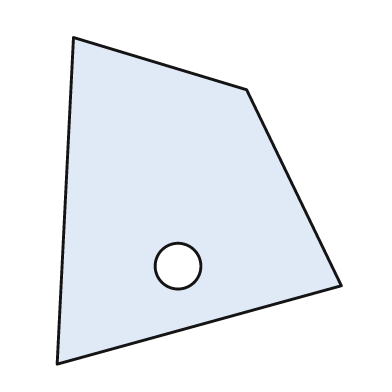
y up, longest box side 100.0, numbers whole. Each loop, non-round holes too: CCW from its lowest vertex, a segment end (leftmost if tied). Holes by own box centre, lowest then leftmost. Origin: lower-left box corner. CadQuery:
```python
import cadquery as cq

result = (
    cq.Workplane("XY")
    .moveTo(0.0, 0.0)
    .lineTo(87.0, 24.0)
    .lineTo(58.0, 84.0)
    .lineTo(5.0, 100.0)
    .close()
    .moveTo(37.0, 30.0)
    .circle(7.0)
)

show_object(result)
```